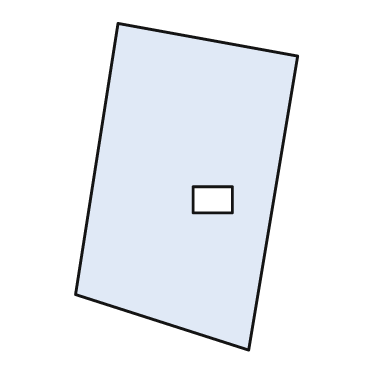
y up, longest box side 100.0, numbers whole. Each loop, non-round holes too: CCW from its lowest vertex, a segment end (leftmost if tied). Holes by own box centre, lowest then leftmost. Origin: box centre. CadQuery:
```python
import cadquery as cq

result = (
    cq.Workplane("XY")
    .moveTo(19.0, -50.0)
    .lineTo(34.0, 40.0)
    .lineTo(-21.0, 50.0)
    .lineTo(-34.0, -33.0)
    .close()
    .moveTo(2.0, -8.0)
    .lineTo(14.0, -8.0)
    .lineTo(14.0, 0.0)
    .lineTo(2.0, 0.0)
    .close()
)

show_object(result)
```